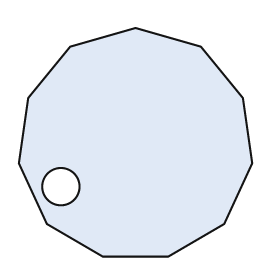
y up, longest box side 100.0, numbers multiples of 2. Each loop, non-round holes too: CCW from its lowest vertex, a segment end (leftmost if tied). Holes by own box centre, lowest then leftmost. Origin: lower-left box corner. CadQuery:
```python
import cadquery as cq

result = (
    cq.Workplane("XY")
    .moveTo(36.0, 0.0)
    .lineTo(64.0, 0.0)
    .lineTo(88.0, 14.0)
    .lineTo(100.0, 40.0)
    .lineTo(96.0, 68.0)
    .lineTo(78.0, 90.0)
    .lineTo(50.0, 98.0)
    .lineTo(22.0, 90.0)
    .lineTo(4.0, 68.0)
    .lineTo(0.0, 40.0)
    .lineTo(12.0, 14.0)
    .close()
    .moveTo(18.0, 30.0)
    .circle(8.0)
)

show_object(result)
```